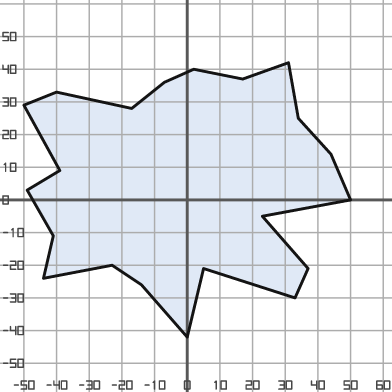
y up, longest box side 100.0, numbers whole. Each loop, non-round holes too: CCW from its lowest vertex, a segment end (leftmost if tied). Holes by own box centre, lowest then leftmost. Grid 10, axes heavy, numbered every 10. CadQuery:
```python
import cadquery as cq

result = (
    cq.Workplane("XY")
    .moveTo(0.0, -42.0)
    .lineTo(5.0, -21.0)
    .lineTo(33.0, -30.0)
    .lineTo(37.0, -21.0)
    .lineTo(23.0, -5.0)
    .lineTo(50.0, 0.0)
    .lineTo(44.0, 14.0)
    .lineTo(34.0, 25.0)
    .lineTo(31.0, 42.0)
    .lineTo(17.0, 37.0)
    .lineTo(2.0, 40.0)
    .lineTo(-7.0, 36.0)
    .lineTo(-17.0, 28.0)
    .lineTo(-40.0, 33.0)
    .lineTo(-50.0, 29.0)
    .lineTo(-39.0, 9.0)
    .lineTo(-49.0, 3.0)
    .lineTo(-41.0, -11.0)
    .lineTo(-44.0, -24.0)
    .lineTo(-23.0, -20.0)
    .lineTo(-14.0, -26.0)
    .close()
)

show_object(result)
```